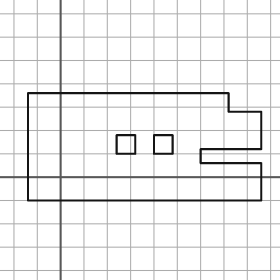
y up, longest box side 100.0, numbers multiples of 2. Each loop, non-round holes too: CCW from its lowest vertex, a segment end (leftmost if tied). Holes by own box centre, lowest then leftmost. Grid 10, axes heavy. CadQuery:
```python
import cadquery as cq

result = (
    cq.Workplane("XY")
    .moveTo(-14.0, -10.0)
    .lineTo(86.0, -10.0)
    .lineTo(86.0, 6.0)
    .lineTo(60.0, 6.0)
    .lineTo(60.0, 12.0)
    .lineTo(86.0, 12.0)
    .lineTo(86.0, 28.0)
    .lineTo(72.0, 28.0)
    .lineTo(72.0, 36.0)
    .lineTo(-14.0, 36.0)
    .close()
    .moveTo(24.0, 10.0)
    .lineTo(32.0, 10.0)
    .lineTo(32.0, 18.0)
    .lineTo(24.0, 18.0)
    .close()
    .moveTo(40.0, 10.0)
    .lineTo(48.0, 10.0)
    .lineTo(48.0, 18.0)
    .lineTo(40.0, 18.0)
    .close()
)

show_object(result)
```